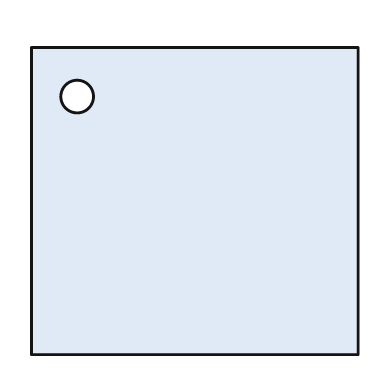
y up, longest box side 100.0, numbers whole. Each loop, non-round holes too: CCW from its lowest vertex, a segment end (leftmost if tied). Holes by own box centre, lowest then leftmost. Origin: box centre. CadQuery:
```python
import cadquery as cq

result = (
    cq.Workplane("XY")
    .moveTo(-50.0, -47.0)
    .lineTo(50.0, -47.0)
    .lineTo(50.0, 47.0)
    .lineTo(-50.0, 47.0)
    .close()
    .moveTo(-36.0, 32.0)
    .circle(5.0)
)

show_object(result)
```